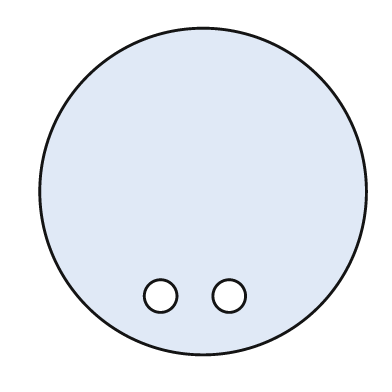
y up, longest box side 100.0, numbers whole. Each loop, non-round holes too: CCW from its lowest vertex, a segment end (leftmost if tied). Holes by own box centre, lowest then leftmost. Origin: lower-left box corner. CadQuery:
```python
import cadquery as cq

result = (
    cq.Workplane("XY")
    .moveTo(50.0, 50.0)
    .circle(50.0)
    .moveTo(37.0, 18.0)
    .circle(5.0)
    .moveTo(58.0, 18.0)
    .circle(5.0)
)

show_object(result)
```